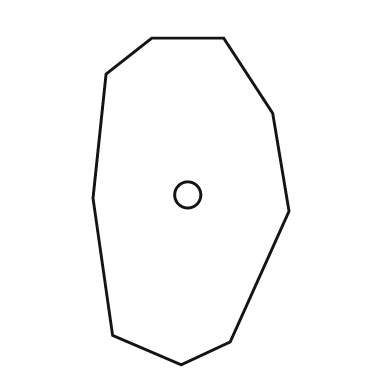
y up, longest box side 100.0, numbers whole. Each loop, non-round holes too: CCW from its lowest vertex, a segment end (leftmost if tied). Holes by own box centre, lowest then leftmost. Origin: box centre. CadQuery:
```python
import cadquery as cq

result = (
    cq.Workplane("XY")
    .moveTo(-3.0, -50.0)
    .lineTo(12.0, -43.0)
    .lineTo(30.0, -3.0)
    .lineTo(25.0, 27.0)
    .lineTo(10.0, 50.0)
    .lineTo(-12.0, 50.0)
    .lineTo(-26.0, 39.0)
    .lineTo(-30.0, 1.0)
    .lineTo(-24.0, -41.0)
    .close()
    .moveTo(-1.0, 2.0)
    .circle(4.0)
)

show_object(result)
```